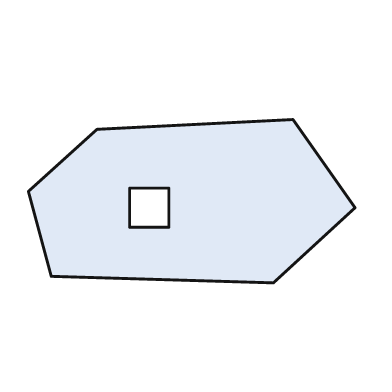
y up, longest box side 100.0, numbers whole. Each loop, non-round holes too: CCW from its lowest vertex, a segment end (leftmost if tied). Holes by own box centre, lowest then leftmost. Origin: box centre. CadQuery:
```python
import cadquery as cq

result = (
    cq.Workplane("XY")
    .moveTo(25.0, -25.0)
    .lineTo(50.0, -2.0)
    .lineTo(31.0, 25.0)
    .lineTo(-29.0, 22.0)
    .lineTo(-50.0, 3.0)
    .lineTo(-43.0, -23.0)
    .close()
    .moveTo(-19.0, -8.0)
    .lineTo(-7.0, -8.0)
    .lineTo(-7.0, 4.0)
    .lineTo(-19.0, 4.0)
    .close()
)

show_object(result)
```